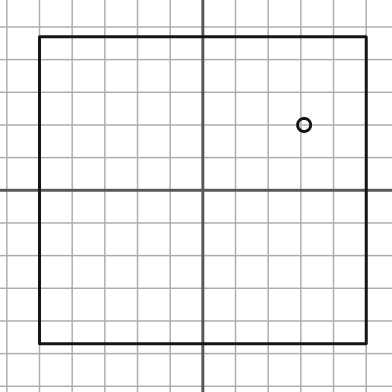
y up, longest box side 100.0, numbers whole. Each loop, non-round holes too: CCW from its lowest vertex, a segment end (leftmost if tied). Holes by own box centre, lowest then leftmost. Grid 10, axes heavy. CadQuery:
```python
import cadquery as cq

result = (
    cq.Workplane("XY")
    .moveTo(-50.0, -47.0)
    .lineTo(50.0, -47.0)
    .lineTo(50.0, 47.0)
    .lineTo(-50.0, 47.0)
    .close()
    .moveTo(31.0, 20.0)
    .circle(2.0)
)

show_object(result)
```